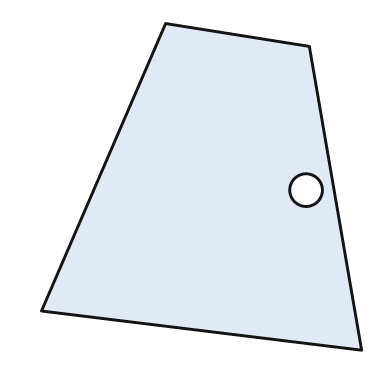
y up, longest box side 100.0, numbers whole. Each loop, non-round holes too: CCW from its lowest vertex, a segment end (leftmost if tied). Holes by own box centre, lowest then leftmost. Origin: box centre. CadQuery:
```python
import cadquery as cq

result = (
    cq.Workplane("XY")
    .moveTo(49.0, -50.0)
    .lineTo(33.0, 43.0)
    .lineTo(-11.0, 50.0)
    .lineTo(-49.0, -38.0)
    .close()
    .moveTo(32.0, -1.0)
    .circle(5.0)
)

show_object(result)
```